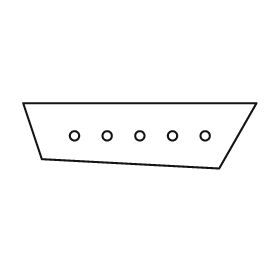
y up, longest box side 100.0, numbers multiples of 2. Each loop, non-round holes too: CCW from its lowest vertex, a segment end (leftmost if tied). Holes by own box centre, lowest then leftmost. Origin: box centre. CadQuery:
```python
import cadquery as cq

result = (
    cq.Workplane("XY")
    .moveTo(34.0, -14.0)
    .lineTo(50.0, 14.0)
    .lineTo(-50.0, 14.0)
    .lineTo(-42.0, -10.0)
    .close()
    .moveTo(-28.0, 0.0)
    .circle(2.0)
    .moveTo(-14.0, 0.0)
    .circle(2.0)
    .moveTo(0.0, 0.0)
    .circle(2.0)
    .moveTo(14.0, 0.0)
    .circle(2.0)
    .moveTo(28.0, 0.0)
    .circle(2.0)
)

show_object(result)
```